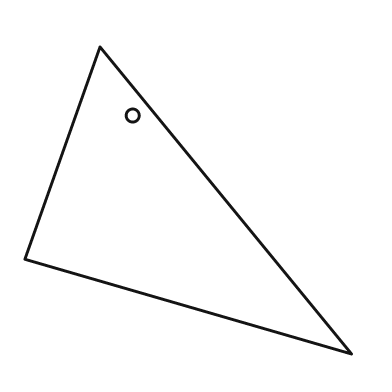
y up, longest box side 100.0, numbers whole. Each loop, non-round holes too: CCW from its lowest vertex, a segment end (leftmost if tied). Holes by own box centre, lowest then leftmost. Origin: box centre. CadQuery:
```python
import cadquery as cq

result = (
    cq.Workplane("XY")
    .moveTo(50.0, -47.0)
    .lineTo(-27.0, 47.0)
    .lineTo(-50.0, -18.0)
    .close()
    .moveTo(-17.0, 26.0)
    .circle(2.0)
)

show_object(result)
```